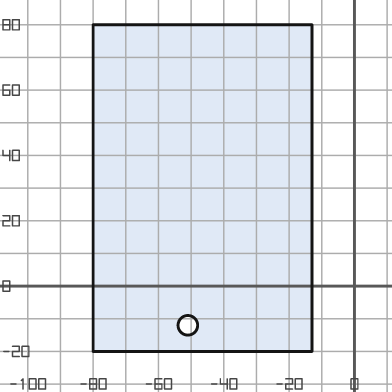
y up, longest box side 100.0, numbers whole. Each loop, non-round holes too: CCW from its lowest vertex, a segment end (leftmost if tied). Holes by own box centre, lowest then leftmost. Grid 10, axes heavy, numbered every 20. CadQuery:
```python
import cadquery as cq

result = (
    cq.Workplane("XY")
    .moveTo(-80.0, -20.0)
    .lineTo(-13.0, -20.0)
    .lineTo(-13.0, 80.0)
    .lineTo(-80.0, 80.0)
    .close()
    .moveTo(-51.0, -12.0)
    .circle(3.0)
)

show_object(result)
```